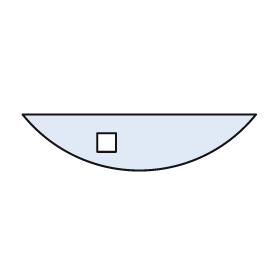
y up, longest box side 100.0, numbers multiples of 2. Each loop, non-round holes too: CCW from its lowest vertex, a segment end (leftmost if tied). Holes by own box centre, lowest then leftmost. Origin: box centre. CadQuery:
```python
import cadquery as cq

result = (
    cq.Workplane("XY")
    .moveTo(-50.0, 12.0)
    .threePointArc((0.0, -12.0), (50.0, 12.0))
    .close()
    .moveTo(-18.0, -4.0)
    .lineTo(-10.0, -4.0)
    .lineTo(-10.0, 4.0)
    .lineTo(-18.0, 4.0)
    .close()
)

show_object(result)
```